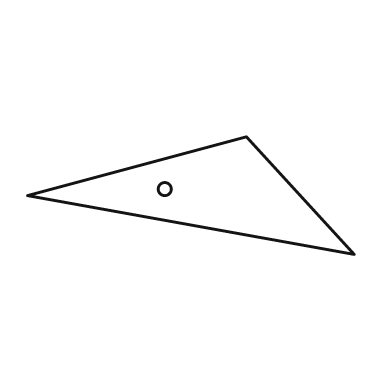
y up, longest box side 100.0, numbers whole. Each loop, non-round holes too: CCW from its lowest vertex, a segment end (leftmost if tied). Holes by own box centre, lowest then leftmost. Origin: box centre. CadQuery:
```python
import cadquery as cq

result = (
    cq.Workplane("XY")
    .moveTo(50.0, -18.0)
    .lineTo(17.0, 18.0)
    .lineTo(-50.0, 0.0)
    .close()
    .moveTo(-8.0, 2.0)
    .circle(2.0)
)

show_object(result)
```